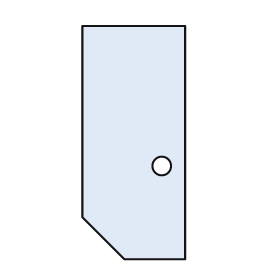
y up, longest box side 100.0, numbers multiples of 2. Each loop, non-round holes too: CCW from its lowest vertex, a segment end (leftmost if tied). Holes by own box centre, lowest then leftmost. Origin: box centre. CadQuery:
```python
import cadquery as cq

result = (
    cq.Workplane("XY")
    .moveTo(-4.0, -50.0)
    .lineTo(22.0, -50.0)
    .lineTo(22.0, 50.0)
    .lineTo(-22.0, 50.0)
    .lineTo(-22.0, -32.0)
    .close()
    .moveTo(12.0, -10.0)
    .circle(4.0)
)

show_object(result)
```